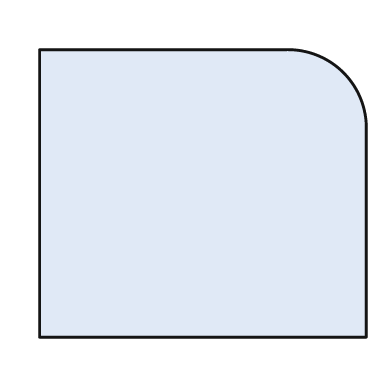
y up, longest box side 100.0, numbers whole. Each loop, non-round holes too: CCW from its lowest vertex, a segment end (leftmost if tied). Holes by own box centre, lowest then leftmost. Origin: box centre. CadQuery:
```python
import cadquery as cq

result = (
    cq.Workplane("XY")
    .moveTo(-50.0, -44.0)
    .lineTo(50.0, -44.0)
    .lineTo(50.0, 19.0)
    .threePointArc((43.0, 37.0), (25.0, 44.0))
    .lineTo(-50.0, 44.0)
    .close()
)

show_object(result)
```